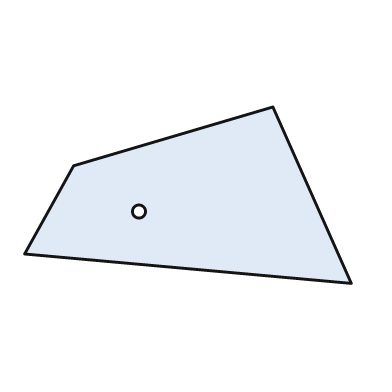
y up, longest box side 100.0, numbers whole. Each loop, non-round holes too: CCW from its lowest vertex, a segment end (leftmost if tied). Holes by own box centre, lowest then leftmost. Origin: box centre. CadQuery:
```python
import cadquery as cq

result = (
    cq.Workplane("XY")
    .moveTo(50.0, -27.0)
    .lineTo(26.0, 27.0)
    .lineTo(-35.0, 9.0)
    .lineTo(-50.0, -18.0)
    .close()
    .moveTo(-15.0, -5.0)
    .circle(2.0)
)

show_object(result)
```